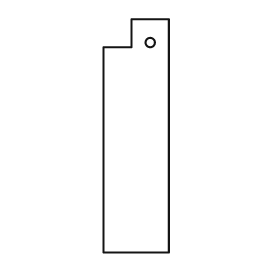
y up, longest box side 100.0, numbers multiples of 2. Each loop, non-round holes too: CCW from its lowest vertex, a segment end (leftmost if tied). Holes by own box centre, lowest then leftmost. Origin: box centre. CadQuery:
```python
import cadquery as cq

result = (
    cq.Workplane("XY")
    .moveTo(-14.0, -50.0)
    .lineTo(14.0, -50.0)
    .lineTo(14.0, 50.0)
    .lineTo(-2.0, 50.0)
    .lineTo(-2.0, 38.0)
    .lineTo(-14.0, 38.0)
    .close()
    .moveTo(6.0, 40.0)
    .circle(2.0)
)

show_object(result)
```